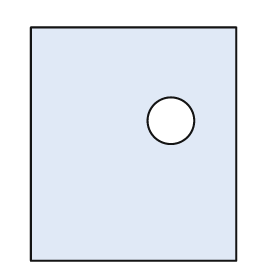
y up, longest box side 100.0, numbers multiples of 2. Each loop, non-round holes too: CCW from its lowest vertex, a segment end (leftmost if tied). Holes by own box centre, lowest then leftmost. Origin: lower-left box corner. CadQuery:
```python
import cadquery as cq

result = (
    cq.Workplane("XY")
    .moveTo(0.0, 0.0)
    .lineTo(88.0, 0.0)
    .lineTo(88.0, 100.0)
    .lineTo(0.0, 100.0)
    .close()
    .moveTo(60.0, 60.0)
    .circle(10.0)
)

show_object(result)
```